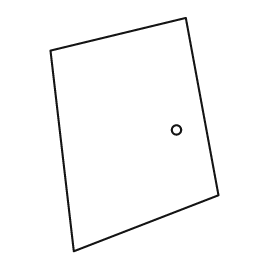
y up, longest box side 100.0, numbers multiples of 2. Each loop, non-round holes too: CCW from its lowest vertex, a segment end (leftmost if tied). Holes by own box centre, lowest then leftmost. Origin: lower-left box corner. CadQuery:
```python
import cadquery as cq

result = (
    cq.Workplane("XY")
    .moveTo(10.0, 0.0)
    .lineTo(72.0, 24.0)
    .lineTo(58.0, 100.0)
    .lineTo(0.0, 86.0)
    .close()
    .moveTo(54.0, 52.0)
    .circle(2.0)
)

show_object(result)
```